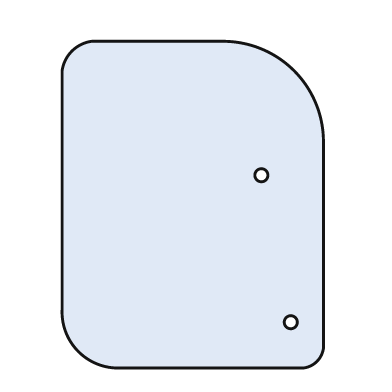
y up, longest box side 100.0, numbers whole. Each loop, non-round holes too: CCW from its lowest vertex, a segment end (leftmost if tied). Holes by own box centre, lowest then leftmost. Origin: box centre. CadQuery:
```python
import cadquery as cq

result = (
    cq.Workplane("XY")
    .moveTo(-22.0, -50.0)
    .lineTo(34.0, -50.0)
    .threePointArc((38.0, -48.0), (40.0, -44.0))
    .lineTo(40.0, 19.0)
    .threePointArc((31.0, 41.0), (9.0, 50.0))
    .lineTo(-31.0, 50.0)
    .threePointArc((-37.0, 47.0), (-40.0, 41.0))
    .lineTo(-40.0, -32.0)
    .threePointArc((-35.0, -45.0), (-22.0, -50.0))
    .close()
    .moveTo(30.0, -36.0)
    .circle(2.0)
    .moveTo(21.0, 9.0)
    .circle(2.0)
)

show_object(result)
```